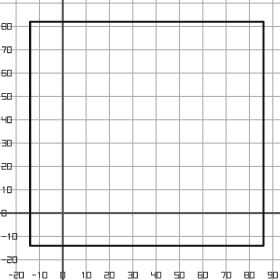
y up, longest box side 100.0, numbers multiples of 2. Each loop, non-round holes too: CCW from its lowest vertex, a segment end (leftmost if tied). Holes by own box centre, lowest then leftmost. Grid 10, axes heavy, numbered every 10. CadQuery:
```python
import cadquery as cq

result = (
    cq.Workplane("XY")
    .moveTo(-14.0, -14.0)
    .lineTo(86.0, -14.0)
    .lineTo(86.0, 82.0)
    .lineTo(-14.0, 82.0)
    .close()
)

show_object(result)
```